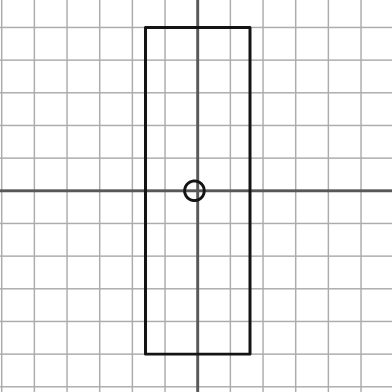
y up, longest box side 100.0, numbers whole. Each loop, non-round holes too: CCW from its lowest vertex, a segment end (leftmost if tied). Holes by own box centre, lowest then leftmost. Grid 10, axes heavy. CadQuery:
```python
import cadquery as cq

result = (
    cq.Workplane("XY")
    .moveTo(-16.0, -50.0)
    .lineTo(16.0, -50.0)
    .lineTo(16.0, 50.0)
    .lineTo(-16.0, 50.0)
    .close()
    .moveTo(-1.0, 0.0)
    .circle(3.0)
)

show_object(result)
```